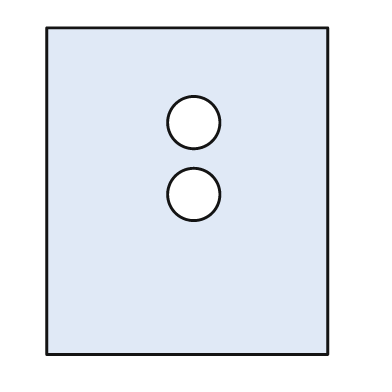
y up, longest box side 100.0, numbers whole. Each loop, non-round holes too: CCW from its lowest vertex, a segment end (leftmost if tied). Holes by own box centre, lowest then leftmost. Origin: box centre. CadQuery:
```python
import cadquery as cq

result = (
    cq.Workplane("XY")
    .moveTo(-43.0, -50.0)
    .lineTo(43.0, -50.0)
    .lineTo(43.0, 50.0)
    .lineTo(-43.0, 50.0)
    .close()
    .moveTo(2.0, -1.0)
    .circle(8.0)
    .moveTo(2.0, 21.0)
    .circle(8.0)
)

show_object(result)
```